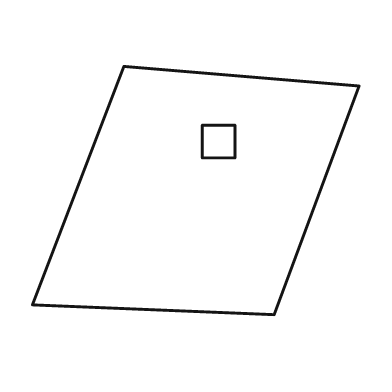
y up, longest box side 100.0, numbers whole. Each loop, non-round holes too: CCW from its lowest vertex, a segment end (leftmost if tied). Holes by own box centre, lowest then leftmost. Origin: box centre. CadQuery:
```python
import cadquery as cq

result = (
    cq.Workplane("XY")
    .moveTo(24.0, -38.0)
    .lineTo(50.0, 32.0)
    .lineTo(-22.0, 38.0)
    .lineTo(-50.0, -35.0)
    .close()
    .moveTo(2.0, 10.0)
    .lineTo(12.0, 10.0)
    .lineTo(12.0, 20.0)
    .lineTo(2.0, 20.0)
    .close()
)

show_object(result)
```